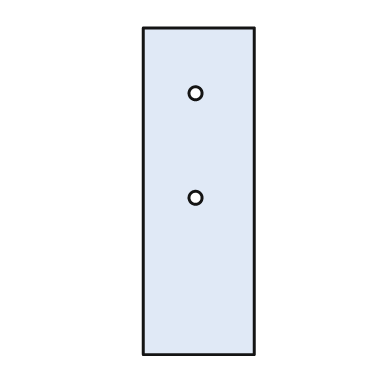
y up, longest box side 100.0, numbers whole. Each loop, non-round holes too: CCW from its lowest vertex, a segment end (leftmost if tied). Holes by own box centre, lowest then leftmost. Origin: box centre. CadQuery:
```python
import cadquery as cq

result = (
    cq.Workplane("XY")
    .moveTo(-17.0, -50.0)
    .lineTo(17.0, -50.0)
    .lineTo(17.0, 50.0)
    .lineTo(-17.0, 50.0)
    .close()
    .moveTo(-1.0, -2.0)
    .circle(2.0)
    .moveTo(-1.0, 30.0)
    .circle(2.0)
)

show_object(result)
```